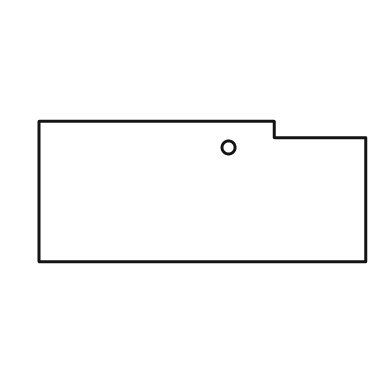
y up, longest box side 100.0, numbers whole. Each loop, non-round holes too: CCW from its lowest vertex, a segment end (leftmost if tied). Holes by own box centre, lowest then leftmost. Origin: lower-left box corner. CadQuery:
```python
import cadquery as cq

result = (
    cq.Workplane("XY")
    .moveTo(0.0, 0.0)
    .lineTo(100.0, 0.0)
    .lineTo(100.0, 38.0)
    .lineTo(72.0, 38.0)
    .lineTo(72.0, 43.0)
    .lineTo(0.0, 43.0)
    .close()
    .moveTo(58.0, 35.0)
    .circle(2.0)
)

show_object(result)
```